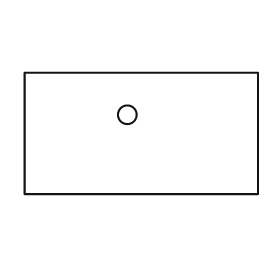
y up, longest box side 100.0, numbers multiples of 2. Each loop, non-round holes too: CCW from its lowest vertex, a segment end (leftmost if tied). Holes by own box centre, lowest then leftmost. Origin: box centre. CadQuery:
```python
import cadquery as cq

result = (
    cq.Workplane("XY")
    .moveTo(-50.0, -26.0)
    .lineTo(50.0, -26.0)
    .lineTo(50.0, 26.0)
    .lineTo(-50.0, 26.0)
    .close()
    .moveTo(-6.0, 8.0)
    .circle(4.0)
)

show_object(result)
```